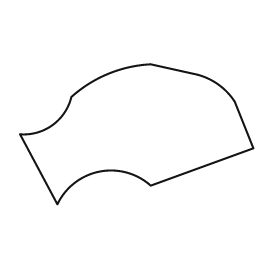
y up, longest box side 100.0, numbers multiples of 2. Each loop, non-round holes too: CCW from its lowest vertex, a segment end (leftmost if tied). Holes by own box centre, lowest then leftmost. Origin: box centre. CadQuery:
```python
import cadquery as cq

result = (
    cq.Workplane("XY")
    .moveTo(-34.0, -30.0)
    .threePointArc((-16.0, -16.0), (6.0, -22.0))
    .lineTo(50.0, -6.0)
    .lineTo(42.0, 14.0)
    .threePointArc((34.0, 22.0), (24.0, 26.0))
    .lineTo(6.0, 30.0)
    .threePointArc((-12.0, 26.0), (-28.0, 16.0))
    .threePointArc((-36.0, 4.0), (-50.0, 0.0))
    .close()
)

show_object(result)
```